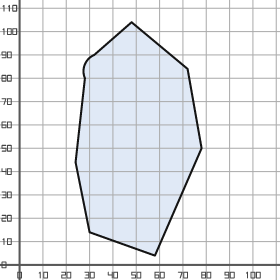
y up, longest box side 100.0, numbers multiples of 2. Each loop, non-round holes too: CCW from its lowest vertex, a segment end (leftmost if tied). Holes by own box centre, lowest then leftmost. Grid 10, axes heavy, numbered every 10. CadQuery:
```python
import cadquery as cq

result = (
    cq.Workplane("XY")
    .moveTo(58.0, 4.0)
    .lineTo(78.0, 50.0)
    .lineTo(72.0, 84.0)
    .lineTo(48.0, 104.0)
    .lineTo(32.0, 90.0)
    .threePointArc((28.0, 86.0), (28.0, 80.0))
    .lineTo(24.0, 44.0)
    .lineTo(30.0, 14.0)
    .close()
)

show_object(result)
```